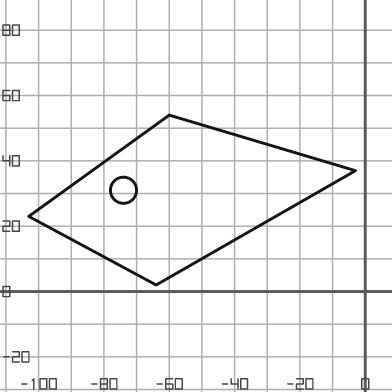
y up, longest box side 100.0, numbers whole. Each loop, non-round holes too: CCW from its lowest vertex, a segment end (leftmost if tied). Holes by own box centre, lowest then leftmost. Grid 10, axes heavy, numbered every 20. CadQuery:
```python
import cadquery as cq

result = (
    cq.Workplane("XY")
    .moveTo(-64.0, 2.0)
    .lineTo(-3.0, 37.0)
    .lineTo(-60.0, 54.0)
    .lineTo(-103.0, 23.0)
    .close()
    .moveTo(-74.0, 31.0)
    .circle(4.0)
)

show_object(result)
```